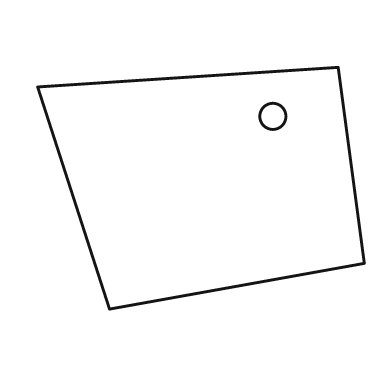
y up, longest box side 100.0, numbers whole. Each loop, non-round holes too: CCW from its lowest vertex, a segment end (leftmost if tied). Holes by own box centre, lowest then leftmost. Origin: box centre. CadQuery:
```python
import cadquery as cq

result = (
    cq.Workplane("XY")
    .moveTo(-28.0, -37.0)
    .lineTo(50.0, -23.0)
    .lineTo(42.0, 37.0)
    .lineTo(-50.0, 31.0)
    .close()
    .moveTo(22.0, 22.0)
    .circle(4.0)
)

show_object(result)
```